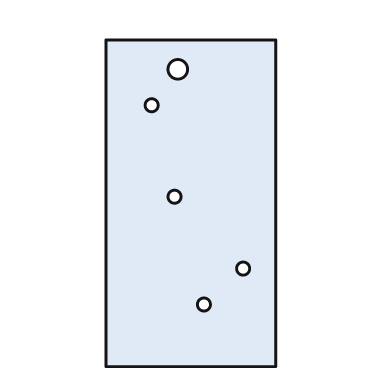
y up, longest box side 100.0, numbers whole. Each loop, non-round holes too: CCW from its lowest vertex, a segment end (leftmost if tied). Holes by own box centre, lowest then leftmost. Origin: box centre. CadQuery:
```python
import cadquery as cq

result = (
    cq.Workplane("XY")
    .moveTo(-26.0, -50.0)
    .lineTo(26.0, -50.0)
    .lineTo(26.0, 50.0)
    .lineTo(-26.0, 50.0)
    .close()
    .moveTo(4.0, -31.0)
    .circle(2.0)
    .moveTo(16.0, -20.0)
    .circle(2.0)
    .moveTo(-5.0, 2.0)
    .circle(2.0)
    .moveTo(-12.0, 30.0)
    .circle(2.0)
    .moveTo(-4.0, 41.0)
    .circle(3.0)
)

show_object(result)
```